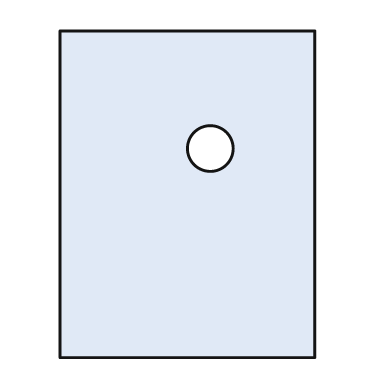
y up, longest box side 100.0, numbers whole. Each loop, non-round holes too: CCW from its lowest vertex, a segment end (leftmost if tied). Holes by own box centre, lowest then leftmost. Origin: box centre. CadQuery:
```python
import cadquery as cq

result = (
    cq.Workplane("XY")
    .moveTo(-39.0, -50.0)
    .lineTo(39.0, -50.0)
    .lineTo(39.0, 50.0)
    .lineTo(-39.0, 50.0)
    .close()
    .moveTo(7.0, 14.0)
    .circle(7.0)
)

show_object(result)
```